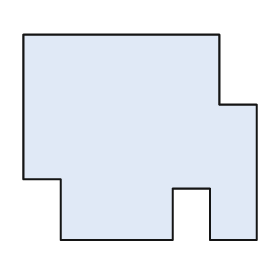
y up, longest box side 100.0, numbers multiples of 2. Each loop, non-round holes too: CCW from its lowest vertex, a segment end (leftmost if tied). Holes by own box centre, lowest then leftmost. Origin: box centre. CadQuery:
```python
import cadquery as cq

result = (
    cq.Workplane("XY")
    .moveTo(-34.0, -44.0)
    .lineTo(14.0, -44.0)
    .lineTo(14.0, -22.0)
    .lineTo(30.0, -22.0)
    .lineTo(30.0, -44.0)
    .lineTo(50.0, -44.0)
    .lineTo(50.0, 14.0)
    .lineTo(34.0, 14.0)
    .lineTo(34.0, 44.0)
    .lineTo(-50.0, 44.0)
    .lineTo(-50.0, -18.0)
    .lineTo(-34.0, -18.0)
    .close()
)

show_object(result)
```